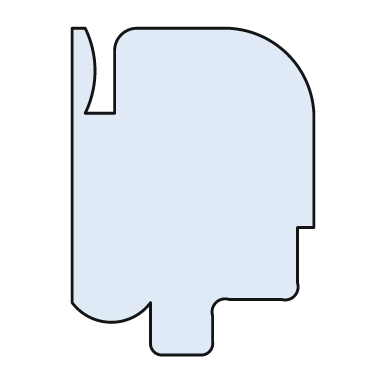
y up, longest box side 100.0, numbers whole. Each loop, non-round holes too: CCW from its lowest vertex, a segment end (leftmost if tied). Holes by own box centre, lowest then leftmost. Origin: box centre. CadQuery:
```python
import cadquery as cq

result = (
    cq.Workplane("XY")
    .moveTo(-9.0, -50.0)
    .lineTo(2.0, -50.0)
    .threePointArc((5.0, -49.0), (6.0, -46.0))
    .lineTo(6.0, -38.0)
    .threePointArc((7.0, -34.0), (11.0, -33.0))
    .lineTo(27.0, -33.0)
    .threePointArc((31.0, -32.0), (32.0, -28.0))
    .lineTo(32.0, -11.0)
    .lineTo(37.0, -11.0)
    .lineTo(37.0, 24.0)
    .threePointArc((29.0, 42.0), (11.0, 50.0))
    .lineTo(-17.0, 50.0)
    .threePointArc((-22.0, 48.0), (-24.0, 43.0))
    .lineTo(-24.0, 24.0)
    .lineTo(-33.0, 24.0)
    .threePointArc((-30.0, 37.0), (-33.0, 50.0))
    .lineTo(-37.0, 50.0)
    .lineTo(-37.0, -34.0)
    .threePointArc((-25.0, -40.0), (-13.0, -34.0))
    .lineTo(-13.0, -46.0)
    .threePointArc((-12.0, -49.0), (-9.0, -50.0))
    .close()
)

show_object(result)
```